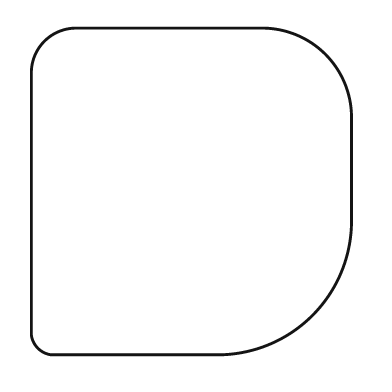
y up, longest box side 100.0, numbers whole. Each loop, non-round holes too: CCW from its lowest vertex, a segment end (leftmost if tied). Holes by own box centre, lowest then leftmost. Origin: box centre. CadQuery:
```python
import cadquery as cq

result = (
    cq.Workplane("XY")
    .moveTo(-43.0, -50.0)
    .lineTo(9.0, -50.0)
    .threePointArc((37.0, -38.0), (49.0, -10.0))
    .lineTo(49.0, 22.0)
    .threePointArc((41.0, 42.0), (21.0, 50.0))
    .lineTo(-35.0, 50.0)
    .threePointArc((-45.0, 46.0), (-49.0, 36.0))
    .lineTo(-49.0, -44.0)
    .threePointArc((-47.0, -48.0), (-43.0, -50.0))
    .close()
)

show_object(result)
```